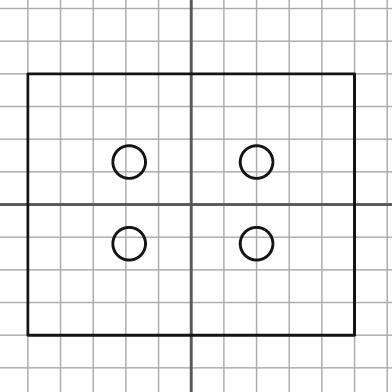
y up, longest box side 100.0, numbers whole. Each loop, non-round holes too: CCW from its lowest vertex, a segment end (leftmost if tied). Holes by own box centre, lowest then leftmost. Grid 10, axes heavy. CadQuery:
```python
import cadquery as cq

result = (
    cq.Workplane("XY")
    .moveTo(-50.0, -40.0)
    .lineTo(50.0, -40.0)
    .lineTo(50.0, 40.0)
    .lineTo(-50.0, 40.0)
    .close()
    .moveTo(-19.0, -12.0)
    .circle(5.0)
    .moveTo(20.0, -12.0)
    .circle(5.0)
    .moveTo(-19.0, 13.0)
    .circle(5.0)
    .moveTo(20.0, 13.0)
    .circle(5.0)
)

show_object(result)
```